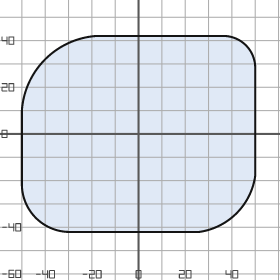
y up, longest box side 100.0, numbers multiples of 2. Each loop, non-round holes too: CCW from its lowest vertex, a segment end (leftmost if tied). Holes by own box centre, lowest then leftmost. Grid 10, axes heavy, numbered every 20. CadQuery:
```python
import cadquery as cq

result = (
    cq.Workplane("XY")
    .moveTo(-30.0, -42.0)
    .lineTo(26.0, -42.0)
    .threePointArc((42.0, -34.0), (50.0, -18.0))
    .lineTo(50.0, 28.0)
    .threePointArc((46.0, 38.0), (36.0, 42.0))
    .lineTo(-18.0, 42.0)
    .threePointArc((-40.0, 32.0), (-50.0, 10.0))
    .lineTo(-50.0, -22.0)
    .threePointArc((-44.0, -36.0), (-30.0, -42.0))
    .close()
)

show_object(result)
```